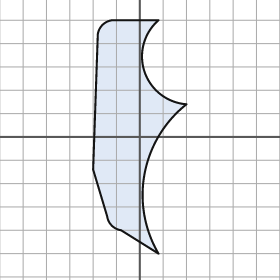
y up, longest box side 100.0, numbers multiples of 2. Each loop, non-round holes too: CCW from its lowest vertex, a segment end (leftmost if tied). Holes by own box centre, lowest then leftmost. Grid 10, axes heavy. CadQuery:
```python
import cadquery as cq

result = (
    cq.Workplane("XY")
    .moveTo(8.0, -50.0)
    .threePointArc((2.0, -16.0), (20.0, 14.0))
    .threePointArc((2.0, 28.0), (8.0, 50.0))
    .lineTo(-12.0, 50.0)
    .threePointArc((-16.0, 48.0), (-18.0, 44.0))
    .lineTo(-20.0, -14.0)
    .lineTo(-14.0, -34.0)
    .threePointArc((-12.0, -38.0), (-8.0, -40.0))
    .close()
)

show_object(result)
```